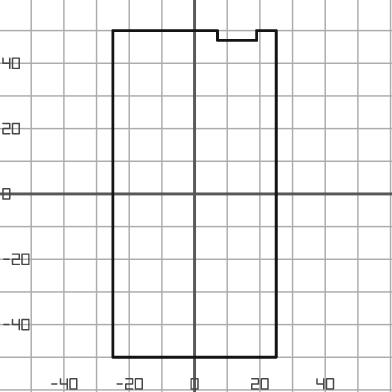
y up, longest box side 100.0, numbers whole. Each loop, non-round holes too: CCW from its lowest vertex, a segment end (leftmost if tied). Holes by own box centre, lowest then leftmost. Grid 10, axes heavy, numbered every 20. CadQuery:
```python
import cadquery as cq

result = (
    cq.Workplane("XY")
    .moveTo(-25.0, -50.0)
    .lineTo(25.0, -50.0)
    .lineTo(25.0, 50.0)
    .lineTo(19.0, 50.0)
    .lineTo(19.0, 47.0)
    .lineTo(7.0, 47.0)
    .lineTo(7.0, 50.0)
    .lineTo(-25.0, 50.0)
    .close()
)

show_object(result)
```